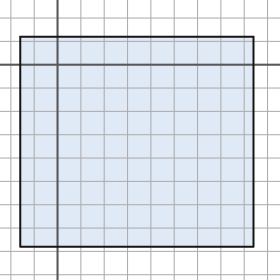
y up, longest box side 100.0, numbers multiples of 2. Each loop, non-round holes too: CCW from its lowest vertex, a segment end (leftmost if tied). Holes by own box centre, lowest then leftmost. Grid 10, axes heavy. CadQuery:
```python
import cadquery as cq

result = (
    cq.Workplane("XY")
    .moveTo(-16.0, -78.0)
    .lineTo(84.0, -78.0)
    .lineTo(84.0, 12.0)
    .lineTo(-16.0, 12.0)
    .close()
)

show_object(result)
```